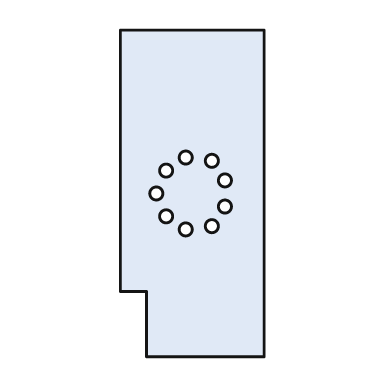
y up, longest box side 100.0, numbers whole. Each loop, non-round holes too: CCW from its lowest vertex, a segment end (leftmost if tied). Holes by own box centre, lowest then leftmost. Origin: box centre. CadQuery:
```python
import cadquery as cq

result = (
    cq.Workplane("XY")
    .moveTo(-14.0, -50.0)
    .lineTo(22.0, -50.0)
    .lineTo(22.0, 50.0)
    .lineTo(-22.0, 50.0)
    .lineTo(-22.0, -30.0)
    .lineTo(-14.0, -30.0)
    .close()
    .moveTo(-2.0, -11.0)
    .circle(2.0)
    .moveTo(6.0, -10.0)
    .circle(2.0)
    .moveTo(-8.0, -7.0)
    .circle(2.0)
    .moveTo(10.0, -4.0)
    .circle(2.0)
    .moveTo(-11.0, 0.0)
    .circle(2.0)
    .moveTo(10.0, 4.0)
    .circle(2.0)
    .moveTo(-8.0, 7.0)
    .circle(2.0)
    .moveTo(6.0, 10.0)
    .circle(2.0)
    .moveTo(-2.0, 11.0)
    .circle(2.0)
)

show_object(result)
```